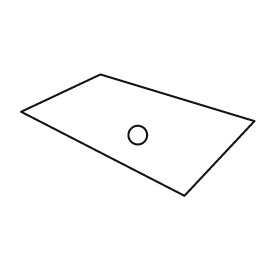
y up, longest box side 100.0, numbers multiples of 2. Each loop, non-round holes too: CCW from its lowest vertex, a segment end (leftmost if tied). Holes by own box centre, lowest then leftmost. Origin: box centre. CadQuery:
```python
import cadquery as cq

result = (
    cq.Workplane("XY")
    .moveTo(20.0, -26.0)
    .lineTo(50.0, 6.0)
    .lineTo(-16.0, 26.0)
    .lineTo(-50.0, 10.0)
    .close()
    .moveTo(0.0, 0.0)
    .circle(4.0)
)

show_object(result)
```